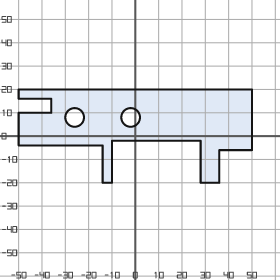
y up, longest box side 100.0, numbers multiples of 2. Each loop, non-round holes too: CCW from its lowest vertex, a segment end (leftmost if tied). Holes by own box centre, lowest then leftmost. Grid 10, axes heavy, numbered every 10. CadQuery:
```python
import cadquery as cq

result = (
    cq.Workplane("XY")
    .moveTo(-14.0, -20.0)
    .lineTo(-10.0, -20.0)
    .lineTo(-10.0, -2.0)
    .lineTo(28.0, -2.0)
    .lineTo(28.0, -20.0)
    .lineTo(36.0, -20.0)
    .lineTo(36.0, -6.0)
    .lineTo(50.0, -6.0)
    .lineTo(50.0, 20.0)
    .lineTo(-50.0, 20.0)
    .lineTo(-50.0, 16.0)
    .lineTo(-36.0, 16.0)
    .lineTo(-36.0, 10.0)
    .lineTo(-50.0, 10.0)
    .lineTo(-50.0, -4.0)
    .lineTo(-14.0, -4.0)
    .close()
    .moveTo(-26.0, 8.0)
    .circle(4.0)
    .moveTo(-2.0, 8.0)
    .circle(4.0)
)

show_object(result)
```